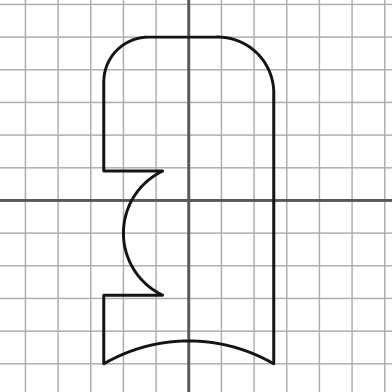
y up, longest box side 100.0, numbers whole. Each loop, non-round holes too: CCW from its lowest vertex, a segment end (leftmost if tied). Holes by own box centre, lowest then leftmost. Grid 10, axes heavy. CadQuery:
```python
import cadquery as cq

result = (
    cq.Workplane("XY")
    .moveTo(-26.0, -50.0)
    .threePointArc((0.0, -43.0), (26.0, -50.0))
    .lineTo(26.0, 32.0)
    .threePointArc((21.0, 45.0), (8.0, 50.0))
    .lineTo(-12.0, 50.0)
    .threePointArc((-22.0, 46.0), (-26.0, 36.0))
    .lineTo(-26.0, 9.0)
    .lineTo(-8.0, 9.0)
    .threePointArc((-20.0, -10.0), (-8.0, -29.0))
    .lineTo(-26.0, -29.0)
    .close()
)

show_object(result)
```